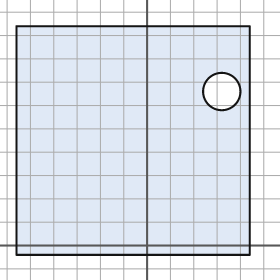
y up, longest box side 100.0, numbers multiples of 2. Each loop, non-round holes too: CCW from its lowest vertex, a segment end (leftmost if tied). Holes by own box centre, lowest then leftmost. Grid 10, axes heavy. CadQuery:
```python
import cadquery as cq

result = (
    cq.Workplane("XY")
    .moveTo(-56.0, -4.0)
    .lineTo(44.0, -4.0)
    .lineTo(44.0, 94.0)
    .lineTo(-56.0, 94.0)
    .close()
    .moveTo(32.0, 66.0)
    .circle(8.0)
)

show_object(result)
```